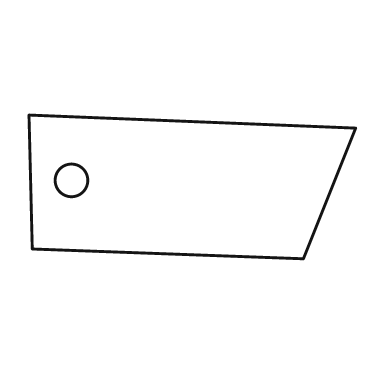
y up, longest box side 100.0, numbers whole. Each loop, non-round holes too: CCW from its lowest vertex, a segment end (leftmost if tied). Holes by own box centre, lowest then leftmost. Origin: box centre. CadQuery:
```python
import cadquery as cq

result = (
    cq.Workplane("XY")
    .moveTo(34.0, -22.0)
    .lineTo(50.0, 18.0)
    .lineTo(-50.0, 22.0)
    .lineTo(-49.0, -19.0)
    .close()
    .moveTo(-37.0, 2.0)
    .circle(5.0)
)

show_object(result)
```